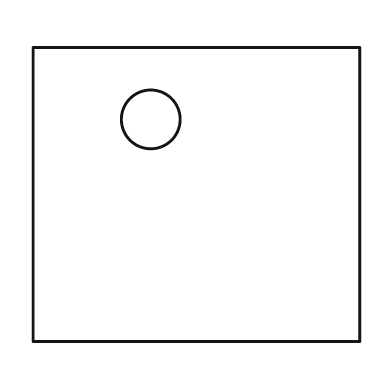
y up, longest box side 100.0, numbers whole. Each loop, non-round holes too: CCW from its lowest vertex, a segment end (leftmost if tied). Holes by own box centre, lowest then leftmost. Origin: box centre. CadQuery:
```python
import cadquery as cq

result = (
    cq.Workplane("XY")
    .moveTo(-50.0, -45.0)
    .lineTo(50.0, -45.0)
    .lineTo(50.0, 45.0)
    .lineTo(-50.0, 45.0)
    .close()
    .moveTo(-14.0, 23.0)
    .circle(9.0)
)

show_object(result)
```